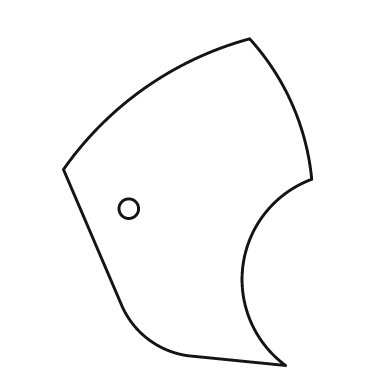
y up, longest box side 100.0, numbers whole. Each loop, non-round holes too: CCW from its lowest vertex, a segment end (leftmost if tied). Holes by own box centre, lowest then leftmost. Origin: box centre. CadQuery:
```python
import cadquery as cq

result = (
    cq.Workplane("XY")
    .moveTo(30.0, -50.0)
    .threePointArc((17.0, -19.0), (38.0, 7.0))
    .threePointArc((32.0, 30.0), (19.0, 50.0))
    .threePointArc((-13.0, 35.0), (-38.0, 10.0))
    .lineTo(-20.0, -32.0)
    .threePointArc((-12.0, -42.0), (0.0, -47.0))
    .close()
    .moveTo(-18.0, -2.0)
    .circle(3.0)
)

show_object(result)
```